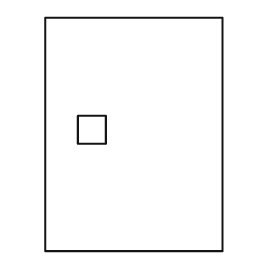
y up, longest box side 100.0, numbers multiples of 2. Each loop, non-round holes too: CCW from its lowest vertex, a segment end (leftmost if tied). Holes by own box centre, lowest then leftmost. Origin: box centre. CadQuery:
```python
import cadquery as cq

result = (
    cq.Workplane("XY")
    .moveTo(-38.0, -50.0)
    .lineTo(38.0, -50.0)
    .lineTo(38.0, 50.0)
    .lineTo(-38.0, 50.0)
    .close()
    .moveTo(-24.0, -4.0)
    .lineTo(-12.0, -4.0)
    .lineTo(-12.0, 8.0)
    .lineTo(-24.0, 8.0)
    .close()
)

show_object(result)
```